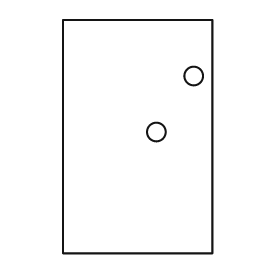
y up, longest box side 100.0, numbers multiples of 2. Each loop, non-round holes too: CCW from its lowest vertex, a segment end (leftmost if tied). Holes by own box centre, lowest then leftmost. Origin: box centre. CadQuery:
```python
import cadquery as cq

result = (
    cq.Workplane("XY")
    .moveTo(-32.0, -50.0)
    .lineTo(32.0, -50.0)
    .lineTo(32.0, 50.0)
    .lineTo(-32.0, 50.0)
    .close()
    .moveTo(8.0, 2.0)
    .circle(4.0)
    .moveTo(24.0, 26.0)
    .circle(4.0)
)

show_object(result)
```